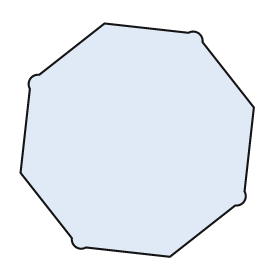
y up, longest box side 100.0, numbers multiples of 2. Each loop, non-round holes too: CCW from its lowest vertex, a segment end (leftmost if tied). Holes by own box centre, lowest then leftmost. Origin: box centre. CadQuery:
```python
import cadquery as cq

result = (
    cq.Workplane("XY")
    .moveTo(14.0, -50.0)
    .lineTo(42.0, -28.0)
    .threePointArc((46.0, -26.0), (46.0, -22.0))
    .lineTo(50.0, 14.0)
    .lineTo(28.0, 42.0)
    .threePointArc((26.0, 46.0), (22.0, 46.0))
    .lineTo(-14.0, 50.0)
    .lineTo(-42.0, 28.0)
    .threePointArc((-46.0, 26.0), (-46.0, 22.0))
    .lineTo(-50.0, -14.0)
    .lineTo(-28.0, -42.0)
    .threePointArc((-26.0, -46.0), (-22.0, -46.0))
    .close()
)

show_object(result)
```